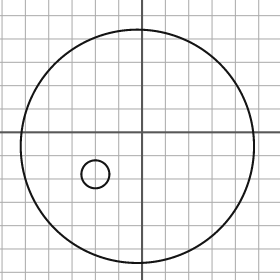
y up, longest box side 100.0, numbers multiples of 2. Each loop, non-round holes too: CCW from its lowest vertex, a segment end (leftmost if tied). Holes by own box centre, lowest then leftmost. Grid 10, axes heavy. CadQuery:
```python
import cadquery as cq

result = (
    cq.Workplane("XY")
    .moveTo(-2.0, -6.0)
    .circle(50.0)
    .moveTo(-20.0, -18.0)
    .circle(6.0)
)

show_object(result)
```